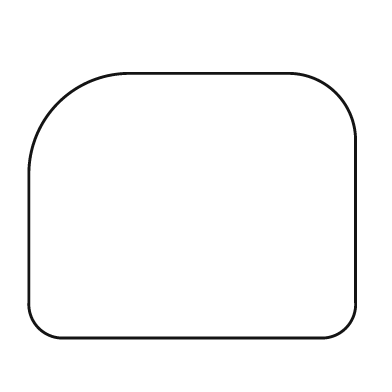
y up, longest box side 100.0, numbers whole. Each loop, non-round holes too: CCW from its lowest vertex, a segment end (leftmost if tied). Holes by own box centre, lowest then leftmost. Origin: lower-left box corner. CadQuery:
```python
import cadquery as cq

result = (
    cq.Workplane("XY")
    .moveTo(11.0, 0.0)
    .lineTo(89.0, 0.0)
    .threePointArc((97.0, 3.0), (100.0, 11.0))
    .lineTo(100.0, 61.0)
    .threePointArc((94.0, 75.0), (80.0, 81.0))
    .lineTo(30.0, 81.0)
    .threePointArc((9.0, 72.0), (0.0, 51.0))
    .lineTo(0.0, 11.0)
    .threePointArc((3.0, 3.0), (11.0, 0.0))
    .close()
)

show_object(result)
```